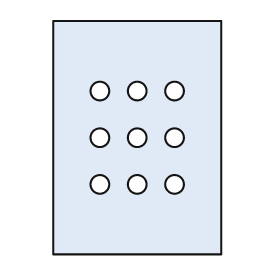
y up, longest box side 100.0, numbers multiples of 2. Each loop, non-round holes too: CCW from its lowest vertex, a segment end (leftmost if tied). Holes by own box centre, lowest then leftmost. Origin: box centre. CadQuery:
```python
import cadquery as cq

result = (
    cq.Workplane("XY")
    .moveTo(-36.0, -50.0)
    .lineTo(36.0, -50.0)
    .lineTo(36.0, 50.0)
    .lineTo(-36.0, 50.0)
    .close()
    .moveTo(-16.0, -20.0)
    .circle(4.0)
    .moveTo(0.0, -20.0)
    .circle(4.0)
    .moveTo(16.0, -20.0)
    .circle(4.0)
    .moveTo(-16.0, 0.0)
    .circle(4.0)
    .moveTo(0.0, 0.0)
    .circle(4.0)
    .moveTo(16.0, 0.0)
    .circle(4.0)
    .moveTo(-16.0, 20.0)
    .circle(4.0)
    .moveTo(0.0, 20.0)
    .circle(4.0)
    .moveTo(16.0, 20.0)
    .circle(4.0)
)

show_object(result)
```